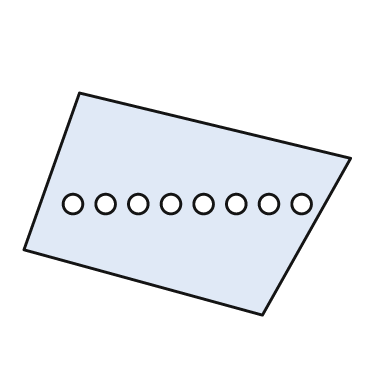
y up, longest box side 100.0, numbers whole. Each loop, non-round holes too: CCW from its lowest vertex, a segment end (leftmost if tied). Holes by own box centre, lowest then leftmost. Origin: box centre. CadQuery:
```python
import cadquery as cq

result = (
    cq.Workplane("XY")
    .moveTo(23.0, -34.0)
    .lineTo(50.0, 14.0)
    .lineTo(-33.0, 34.0)
    .lineTo(-50.0, -14.0)
    .close()
    .moveTo(-35.0, 0.0)
    .circle(3.0)
    .moveTo(-25.0, 0.0)
    .circle(3.0)
    .moveTo(-15.0, 0.0)
    .circle(3.0)
    .moveTo(-5.0, 0.0)
    .circle(3.0)
    .moveTo(5.0, 0.0)
    .circle(3.0)
    .moveTo(15.0, 0.0)
    .circle(3.0)
    .moveTo(25.0, 0.0)
    .circle(3.0)
    .moveTo(35.0, 0.0)
    .circle(3.0)
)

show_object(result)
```